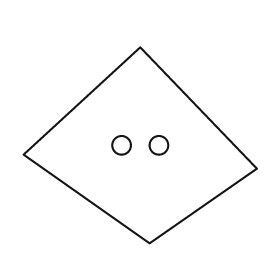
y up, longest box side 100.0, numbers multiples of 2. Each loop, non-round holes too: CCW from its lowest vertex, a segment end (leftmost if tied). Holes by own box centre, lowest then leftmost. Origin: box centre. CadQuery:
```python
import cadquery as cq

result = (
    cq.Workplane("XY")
    .moveTo(4.0, -42.0)
    .lineTo(50.0, -10.0)
    .lineTo(0.0, 42.0)
    .lineTo(-50.0, -4.0)
    .close()
    .moveTo(-8.0, 0.0)
    .circle(4.0)
    .moveTo(8.0, 0.0)
    .circle(4.0)
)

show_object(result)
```